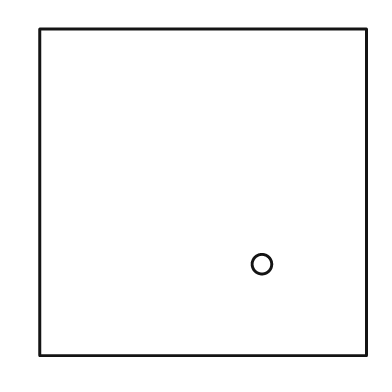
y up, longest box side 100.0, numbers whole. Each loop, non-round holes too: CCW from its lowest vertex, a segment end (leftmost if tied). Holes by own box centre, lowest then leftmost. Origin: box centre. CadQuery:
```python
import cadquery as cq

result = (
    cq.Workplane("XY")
    .moveTo(-50.0, -50.0)
    .lineTo(50.0, -50.0)
    .lineTo(50.0, 50.0)
    .lineTo(-50.0, 50.0)
    .close()
    .moveTo(18.0, -22.0)
    .circle(3.0)
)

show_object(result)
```